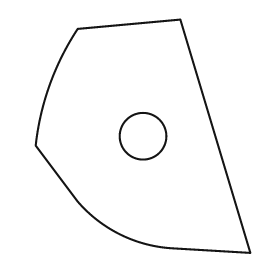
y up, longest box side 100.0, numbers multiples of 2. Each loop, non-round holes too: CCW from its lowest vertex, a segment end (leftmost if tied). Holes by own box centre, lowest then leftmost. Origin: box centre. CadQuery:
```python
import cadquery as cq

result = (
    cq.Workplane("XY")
    .moveTo(46.0, -50.0)
    .lineTo(16.0, 50.0)
    .lineTo(-28.0, 46.0)
    .threePointArc((-40.0, 22.0), (-46.0, -4.0))
    .lineTo(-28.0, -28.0)
    .threePointArc((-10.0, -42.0), (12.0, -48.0))
    .close()
    .moveTo(0.0, 0.0)
    .circle(10.0)
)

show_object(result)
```